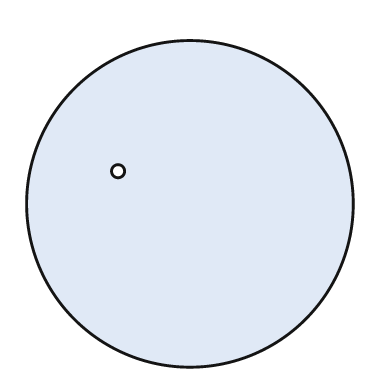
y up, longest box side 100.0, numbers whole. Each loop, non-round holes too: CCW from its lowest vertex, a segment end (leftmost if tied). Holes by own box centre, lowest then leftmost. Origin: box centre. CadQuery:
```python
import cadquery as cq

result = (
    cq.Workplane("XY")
    .moveTo(0.0, 0.0)
    .circle(50.0)
    .moveTo(-22.0, 10.0)
    .circle(2.0)
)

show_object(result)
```